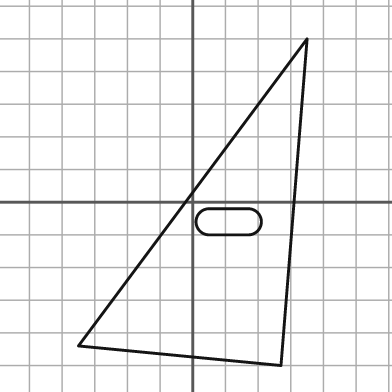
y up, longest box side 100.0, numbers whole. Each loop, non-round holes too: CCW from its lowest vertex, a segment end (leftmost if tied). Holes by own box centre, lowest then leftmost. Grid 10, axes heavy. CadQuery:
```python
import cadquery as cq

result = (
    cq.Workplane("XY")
    .moveTo(27.0, -50.0)
    .lineTo(35.0, 50.0)
    .lineTo(-35.0, -44.0)
    .close()
    .moveTo(5.0, -10.0)
    .lineTo(17.0, -10.0)
    .threePointArc((21.0, -6.0), (17.0, -2.0))
    .lineTo(5.0, -2.0)
    .threePointArc((1.0, -6.0), (5.0, -10.0))
    .close()
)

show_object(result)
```